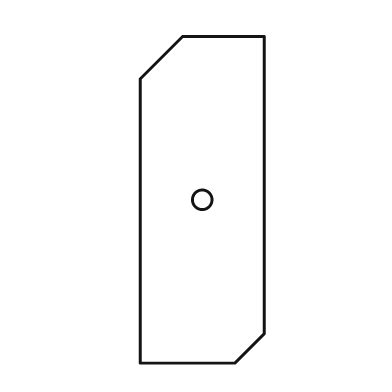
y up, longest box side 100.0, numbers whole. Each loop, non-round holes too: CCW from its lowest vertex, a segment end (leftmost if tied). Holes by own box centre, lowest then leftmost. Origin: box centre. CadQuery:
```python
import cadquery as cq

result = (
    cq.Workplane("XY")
    .moveTo(-19.0, -50.0)
    .lineTo(10.0, -50.0)
    .lineTo(19.0, -41.0)
    .lineTo(19.0, 50.0)
    .lineTo(-6.0, 50.0)
    .lineTo(-19.0, 37.0)
    .close()
    .moveTo(0.0, 0.0)
    .circle(3.0)
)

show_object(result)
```